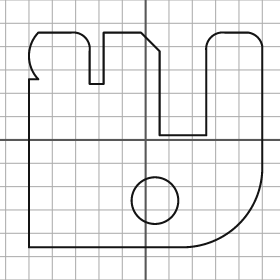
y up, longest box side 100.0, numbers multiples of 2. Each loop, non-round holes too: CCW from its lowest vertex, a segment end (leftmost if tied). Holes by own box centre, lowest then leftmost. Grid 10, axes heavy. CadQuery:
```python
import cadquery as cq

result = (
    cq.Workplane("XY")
    .moveTo(-50.0, -46.0)
    .lineTo(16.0, -46.0)
    .threePointArc((40.0, -36.0), (50.0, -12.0))
    .lineTo(50.0, 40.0)
    .threePointArc((48.0, 44.0), (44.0, 46.0))
    .lineTo(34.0, 46.0)
    .threePointArc((28.0, 44.0), (26.0, 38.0))
    .lineTo(26.0, 2.0)
    .lineTo(6.0, 2.0)
    .lineTo(6.0, 38.0)
    .lineTo(-2.0, 46.0)
    .lineTo(-18.0, 46.0)
    .lineTo(-18.0, 24.0)
    .lineTo(-24.0, 24.0)
    .lineTo(-24.0, 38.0)
    .threePointArc((-26.0, 44.0), (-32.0, 46.0))
    .lineTo(-46.0, 46.0)
    .threePointArc((-50.0, 36.0), (-46.0, 26.0))
    .lineTo(-50.0, 26.0)
    .close()
    .moveTo(4.0, -26.0)
    .circle(10.0)
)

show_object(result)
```